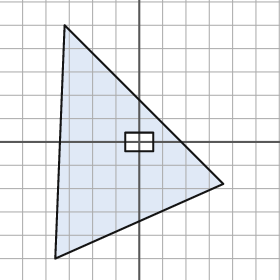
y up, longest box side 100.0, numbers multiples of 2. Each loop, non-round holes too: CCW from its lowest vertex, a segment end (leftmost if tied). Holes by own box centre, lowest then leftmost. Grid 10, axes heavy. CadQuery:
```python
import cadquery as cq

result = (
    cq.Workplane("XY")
    .moveTo(-36.0, -50.0)
    .lineTo(36.0, -18.0)
    .lineTo(-32.0, 50.0)
    .close()
    .moveTo(-6.0, -4.0)
    .lineTo(6.0, -4.0)
    .lineTo(6.0, 4.0)
    .lineTo(-6.0, 4.0)
    .close()
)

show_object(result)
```